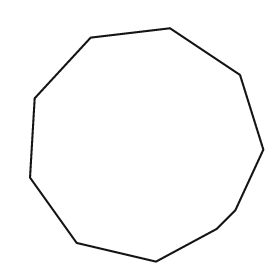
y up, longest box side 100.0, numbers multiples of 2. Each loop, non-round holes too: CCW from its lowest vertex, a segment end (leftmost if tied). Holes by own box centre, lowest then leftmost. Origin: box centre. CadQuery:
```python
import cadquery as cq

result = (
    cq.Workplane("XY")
    .moveTo(4.0, -50.0)
    .lineTo(30.0, -36.0)
    .lineTo(38.0, -28.0)
    .lineTo(50.0, -2.0)
    .lineTo(40.0, 30.0)
    .lineTo(10.0, 50.0)
    .lineTo(-24.0, 46.0)
    .lineTo(-48.0, 20.0)
    .lineTo(-50.0, -14.0)
    .lineTo(-30.0, -42.0)
    .close()
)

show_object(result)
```